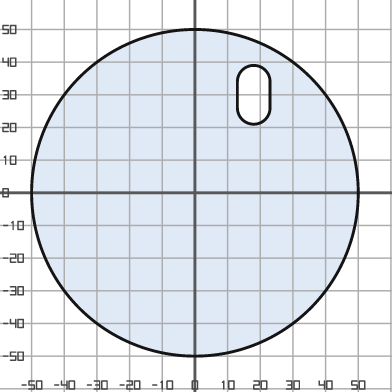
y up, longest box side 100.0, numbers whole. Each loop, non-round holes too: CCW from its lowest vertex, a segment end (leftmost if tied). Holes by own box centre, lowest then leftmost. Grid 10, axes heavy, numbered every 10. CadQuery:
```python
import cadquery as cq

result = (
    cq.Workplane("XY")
    .moveTo(0.0, 0.0)
    .circle(50.0)
    .moveTo(13.0, 26.0)
    .threePointArc((18.0, 21.0), (23.0, 26.0))
    .lineTo(23.0, 34.0)
    .threePointArc((18.0, 39.0), (13.0, 34.0))
    .close()
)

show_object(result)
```